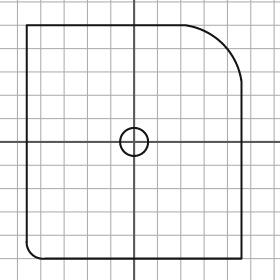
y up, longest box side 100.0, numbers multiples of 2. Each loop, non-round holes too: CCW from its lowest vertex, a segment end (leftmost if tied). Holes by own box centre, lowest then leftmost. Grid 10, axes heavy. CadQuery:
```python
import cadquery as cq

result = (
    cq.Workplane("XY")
    .moveTo(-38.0, -50.0)
    .lineTo(46.0, -50.0)
    .lineTo(46.0, 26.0)
    .threePointArc((38.0, 42.0), (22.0, 50.0))
    .lineTo(-46.0, 50.0)
    .lineTo(-46.0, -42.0)
    .threePointArc((-44.0, -48.0), (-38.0, -50.0))
    .close()
    .moveTo(0.0, 0.0)
    .circle(6.0)
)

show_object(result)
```